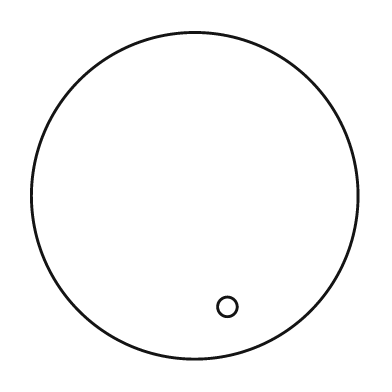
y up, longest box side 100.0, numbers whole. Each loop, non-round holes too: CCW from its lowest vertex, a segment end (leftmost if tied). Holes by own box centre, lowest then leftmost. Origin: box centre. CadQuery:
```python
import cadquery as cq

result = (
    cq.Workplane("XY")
    .moveTo(0.0, 0.0)
    .circle(50.0)
    .moveTo(10.0, -34.0)
    .circle(3.0)
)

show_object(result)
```